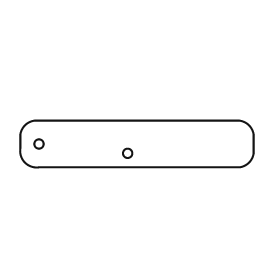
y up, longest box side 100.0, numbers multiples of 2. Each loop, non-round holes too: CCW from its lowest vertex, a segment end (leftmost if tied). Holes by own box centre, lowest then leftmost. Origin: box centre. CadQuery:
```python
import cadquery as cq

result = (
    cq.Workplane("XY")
    .moveTo(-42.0, -10.0)
    .lineTo(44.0, -10.0)
    .threePointArc((48.0, -8.0), (50.0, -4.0))
    .lineTo(50.0, 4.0)
    .threePointArc((48.0, 8.0), (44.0, 10.0))
    .lineTo(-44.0, 10.0)
    .threePointArc((-48.0, 8.0), (-50.0, 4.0))
    .lineTo(-50.0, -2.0)
    .threePointArc((-48.0, -8.0), (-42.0, -10.0))
    .close()
    .moveTo(-4.0, -4.0)
    .circle(2.0)
    .moveTo(-42.0, 0.0)
    .circle(2.0)
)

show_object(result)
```